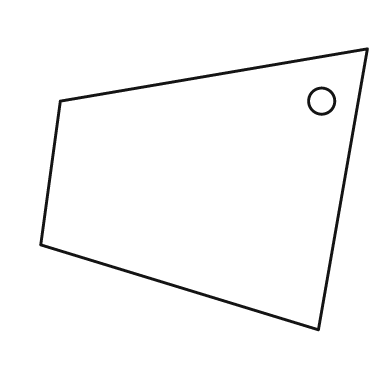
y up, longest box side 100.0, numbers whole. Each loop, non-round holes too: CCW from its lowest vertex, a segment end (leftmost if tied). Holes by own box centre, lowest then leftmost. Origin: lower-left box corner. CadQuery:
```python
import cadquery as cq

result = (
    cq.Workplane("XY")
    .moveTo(85.0, 0.0)
    .lineTo(100.0, 86.0)
    .lineTo(6.0, 70.0)
    .lineTo(0.0, 26.0)
    .close()
    .moveTo(86.0, 70.0)
    .circle(4.0)
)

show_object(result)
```